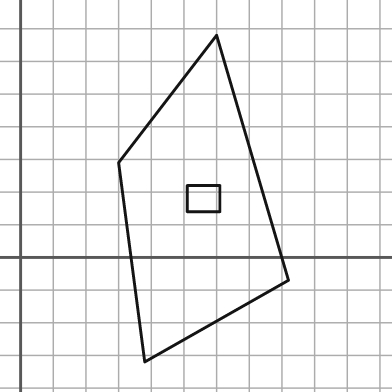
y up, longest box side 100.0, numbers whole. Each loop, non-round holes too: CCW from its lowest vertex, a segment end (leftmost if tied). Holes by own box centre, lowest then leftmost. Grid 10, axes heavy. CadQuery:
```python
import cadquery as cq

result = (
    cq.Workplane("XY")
    .moveTo(38.0, -32.0)
    .lineTo(82.0, -7.0)
    .lineTo(60.0, 68.0)
    .lineTo(30.0, 29.0)
    .close()
    .moveTo(51.0, 14.0)
    .lineTo(61.0, 14.0)
    .lineTo(61.0, 22.0)
    .lineTo(51.0, 22.0)
    .close()
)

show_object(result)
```